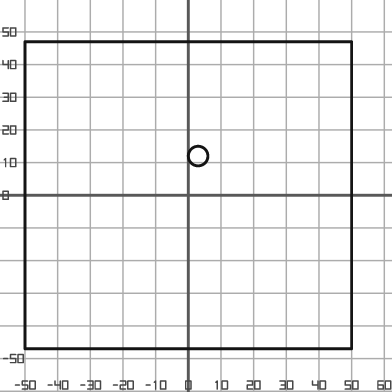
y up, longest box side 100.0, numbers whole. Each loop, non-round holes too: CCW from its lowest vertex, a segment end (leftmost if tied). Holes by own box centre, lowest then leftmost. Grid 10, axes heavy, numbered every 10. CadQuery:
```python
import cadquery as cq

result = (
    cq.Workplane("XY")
    .moveTo(-50.0, -47.0)
    .lineTo(50.0, -47.0)
    .lineTo(50.0, 47.0)
    .lineTo(-50.0, 47.0)
    .close()
    .moveTo(3.0, 12.0)
    .circle(3.0)
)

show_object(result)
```